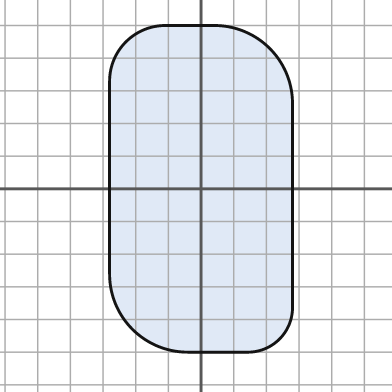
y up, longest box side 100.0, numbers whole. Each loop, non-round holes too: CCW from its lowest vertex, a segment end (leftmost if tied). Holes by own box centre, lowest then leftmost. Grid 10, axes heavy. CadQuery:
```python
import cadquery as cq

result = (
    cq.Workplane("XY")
    .moveTo(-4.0, -50.0)
    .lineTo(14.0, -50.0)
    .threePointArc((24.0, -46.0), (28.0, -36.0))
    .lineTo(28.0, 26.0)
    .threePointArc((21.0, 43.0), (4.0, 50.0))
    .lineTo(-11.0, 50.0)
    .threePointArc((-23.0, 45.0), (-28.0, 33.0))
    .lineTo(-28.0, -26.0)
    .threePointArc((-21.0, -43.0), (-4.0, -50.0))
    .close()
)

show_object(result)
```